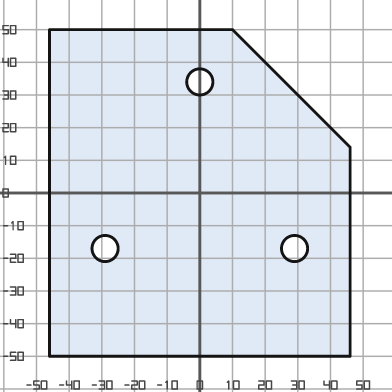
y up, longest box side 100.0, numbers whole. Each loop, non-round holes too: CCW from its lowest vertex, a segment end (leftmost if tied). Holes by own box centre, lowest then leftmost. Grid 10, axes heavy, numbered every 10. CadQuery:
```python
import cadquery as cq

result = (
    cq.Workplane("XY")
    .moveTo(-46.0, -50.0)
    .lineTo(46.0, -50.0)
    .lineTo(46.0, 14.0)
    .lineTo(10.0, 50.0)
    .lineTo(-46.0, 50.0)
    .close()
    .moveTo(-29.0, -17.0)
    .circle(4.0)
    .moveTo(29.0, -17.0)
    .circle(4.0)
    .moveTo(0.0, 34.0)
    .circle(4.0)
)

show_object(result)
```